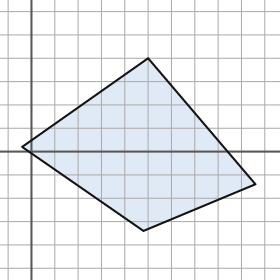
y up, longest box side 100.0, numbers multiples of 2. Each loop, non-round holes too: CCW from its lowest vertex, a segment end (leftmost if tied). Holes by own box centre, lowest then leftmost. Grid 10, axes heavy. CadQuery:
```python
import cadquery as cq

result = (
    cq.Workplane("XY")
    .moveTo(48.0, -34.0)
    .lineTo(96.0, -14.0)
    .lineTo(50.0, 40.0)
    .lineTo(-4.0, 2.0)
    .close()
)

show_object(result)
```